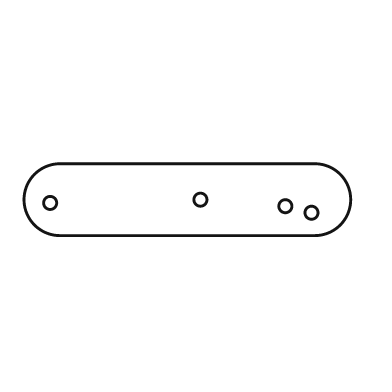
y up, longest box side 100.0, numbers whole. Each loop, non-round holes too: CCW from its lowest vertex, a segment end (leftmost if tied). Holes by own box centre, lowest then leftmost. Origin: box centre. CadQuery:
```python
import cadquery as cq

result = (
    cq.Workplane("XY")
    .moveTo(-39.0, -11.0)
    .lineTo(39.0, -11.0)
    .threePointArc((50.0, 0.0), (39.0, 11.0))
    .lineTo(-39.0, 11.0)
    .threePointArc((-50.0, 0.0), (-39.0, -11.0))
    .close()
    .moveTo(38.0, -4.0)
    .circle(2.0)
    .moveTo(30.0, -2.0)
    .circle(2.0)
    .moveTo(-42.0, -1.0)
    .circle(2.0)
    .moveTo(4.0, 0.0)
    .circle(2.0)
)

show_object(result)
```